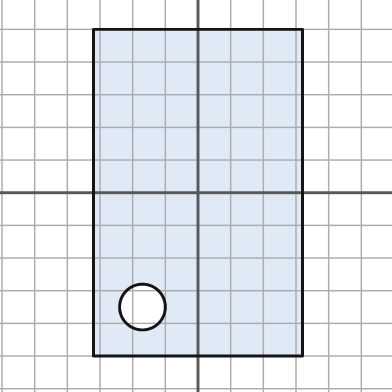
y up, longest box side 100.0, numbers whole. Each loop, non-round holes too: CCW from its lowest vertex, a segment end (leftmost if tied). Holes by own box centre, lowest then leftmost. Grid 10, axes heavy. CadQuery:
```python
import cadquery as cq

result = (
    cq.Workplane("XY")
    .moveTo(-32.0, -50.0)
    .lineTo(32.0, -50.0)
    .lineTo(32.0, 50.0)
    .lineTo(-32.0, 50.0)
    .close()
    .moveTo(-17.0, -35.0)
    .circle(7.0)
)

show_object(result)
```